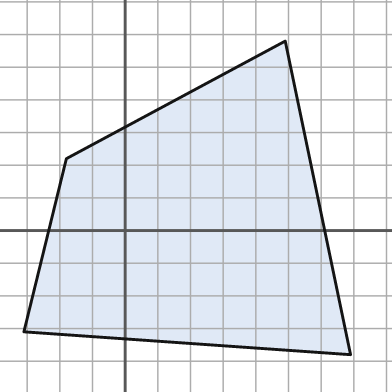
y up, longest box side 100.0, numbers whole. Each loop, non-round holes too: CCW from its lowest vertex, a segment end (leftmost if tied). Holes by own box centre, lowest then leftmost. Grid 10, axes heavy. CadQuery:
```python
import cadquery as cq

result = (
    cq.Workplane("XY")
    .moveTo(69.0, -38.0)
    .lineTo(49.0, 58.0)
    .lineTo(-18.0, 22.0)
    .lineTo(-31.0, -31.0)
    .close()
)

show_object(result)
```